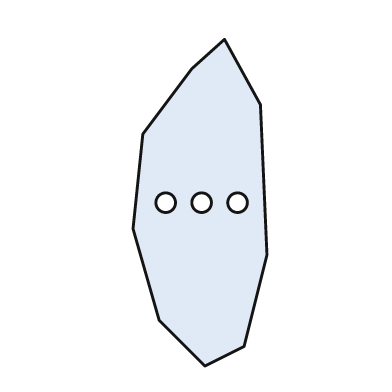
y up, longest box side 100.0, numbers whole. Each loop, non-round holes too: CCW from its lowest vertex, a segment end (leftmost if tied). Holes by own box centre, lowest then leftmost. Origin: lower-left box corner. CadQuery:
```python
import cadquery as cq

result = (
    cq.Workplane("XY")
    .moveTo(22.0, 0.0)
    .lineTo(34.0, 6.0)
    .lineTo(41.0, 34.0)
    .lineTo(39.0, 80.0)
    .lineTo(28.0, 100.0)
    .lineTo(18.0, 91.0)
    .lineTo(3.0, 71.0)
    .lineTo(0.0, 42.0)
    .lineTo(8.0, 14.0)
    .close()
    .moveTo(10.0, 50.0)
    .circle(3.0)
    .moveTo(21.0, 50.0)
    .circle(3.0)
    .moveTo(32.0, 50.0)
    .circle(3.0)
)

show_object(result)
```